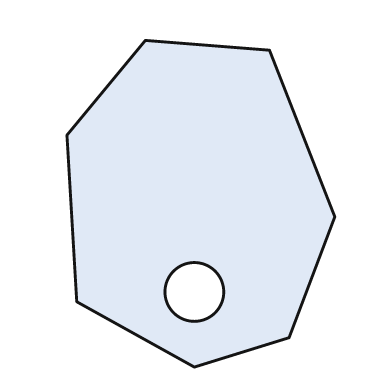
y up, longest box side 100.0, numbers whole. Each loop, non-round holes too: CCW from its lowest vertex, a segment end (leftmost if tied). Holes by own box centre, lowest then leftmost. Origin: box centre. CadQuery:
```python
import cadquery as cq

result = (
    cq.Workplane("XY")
    .moveTo(-2.0, -50.0)
    .lineTo(27.0, -41.0)
    .lineTo(41.0, -4.0)
    .lineTo(21.0, 47.0)
    .lineTo(-17.0, 50.0)
    .lineTo(-41.0, 21.0)
    .lineTo(-38.0, -30.0)
    .close()
    .moveTo(-2.0, -27.0)
    .circle(9.0)
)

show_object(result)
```